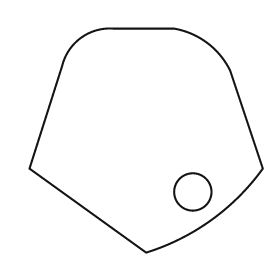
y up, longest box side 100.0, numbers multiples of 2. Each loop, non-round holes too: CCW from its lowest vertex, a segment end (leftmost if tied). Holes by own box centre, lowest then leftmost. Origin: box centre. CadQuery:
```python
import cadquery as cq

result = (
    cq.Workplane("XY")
    .moveTo(0.0, -48.0)
    .threePointArc((28.0, -34.0), (50.0, -12.0))
    .lineTo(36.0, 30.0)
    .threePointArc((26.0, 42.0), (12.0, 48.0))
    .lineTo(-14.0, 48.0)
    .threePointArc((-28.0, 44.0), (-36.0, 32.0))
    .lineTo(-50.0, -12.0)
    .close()
    .moveTo(20.0, -22.0)
    .circle(8.0)
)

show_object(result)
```